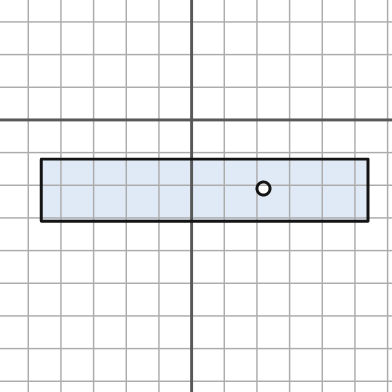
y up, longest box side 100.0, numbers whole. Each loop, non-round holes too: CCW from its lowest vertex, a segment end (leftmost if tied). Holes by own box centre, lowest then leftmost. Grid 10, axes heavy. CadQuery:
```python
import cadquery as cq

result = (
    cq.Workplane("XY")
    .moveTo(-46.0, -31.0)
    .lineTo(54.0, -31.0)
    .lineTo(54.0, -12.0)
    .lineTo(-46.0, -12.0)
    .close()
    .moveTo(22.0, -21.0)
    .circle(2.0)
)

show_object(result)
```